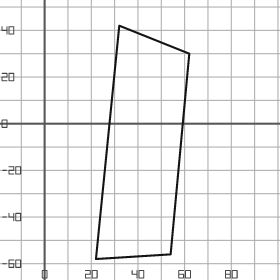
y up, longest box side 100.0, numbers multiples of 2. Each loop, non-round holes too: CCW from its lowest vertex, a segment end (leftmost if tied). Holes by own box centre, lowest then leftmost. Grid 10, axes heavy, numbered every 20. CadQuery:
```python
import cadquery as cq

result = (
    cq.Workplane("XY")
    .moveTo(22.0, -58.0)
    .lineTo(54.0, -56.0)
    .lineTo(62.0, 30.0)
    .lineTo(32.0, 42.0)
    .close()
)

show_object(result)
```